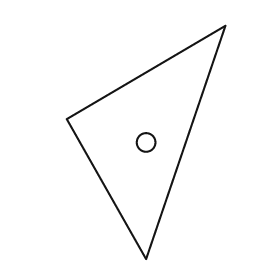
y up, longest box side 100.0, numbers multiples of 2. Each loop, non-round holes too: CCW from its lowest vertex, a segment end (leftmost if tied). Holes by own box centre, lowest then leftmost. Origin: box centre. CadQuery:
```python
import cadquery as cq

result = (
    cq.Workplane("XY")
    .moveTo(0.0, -50.0)
    .lineTo(34.0, 50.0)
    .lineTo(-34.0, 10.0)
    .close()
    .moveTo(0.0, 0.0)
    .circle(4.0)
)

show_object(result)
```